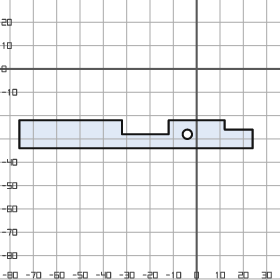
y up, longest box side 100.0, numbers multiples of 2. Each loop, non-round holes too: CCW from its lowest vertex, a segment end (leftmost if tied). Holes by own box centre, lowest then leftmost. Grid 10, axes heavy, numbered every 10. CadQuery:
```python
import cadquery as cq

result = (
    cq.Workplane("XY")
    .moveTo(-76.0, -34.0)
    .lineTo(24.0, -34.0)
    .lineTo(24.0, -26.0)
    .lineTo(12.0, -26.0)
    .lineTo(12.0, -22.0)
    .lineTo(-12.0, -22.0)
    .lineTo(-12.0, -28.0)
    .lineTo(-32.0, -28.0)
    .lineTo(-32.0, -22.0)
    .lineTo(-76.0, -22.0)
    .close()
    .moveTo(-4.0, -28.0)
    .circle(2.0)
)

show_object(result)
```